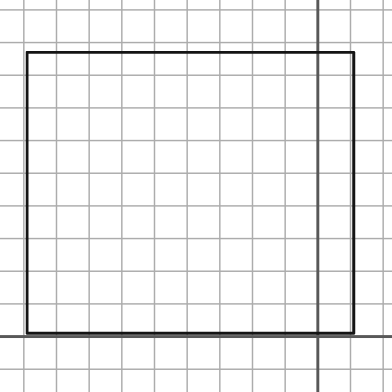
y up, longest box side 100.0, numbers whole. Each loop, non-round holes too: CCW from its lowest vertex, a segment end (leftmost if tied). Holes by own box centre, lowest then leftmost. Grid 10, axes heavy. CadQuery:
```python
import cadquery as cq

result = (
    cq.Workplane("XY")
    .moveTo(-89.0, 1.0)
    .lineTo(11.0, 1.0)
    .lineTo(11.0, 87.0)
    .lineTo(-89.0, 87.0)
    .close()
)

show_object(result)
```